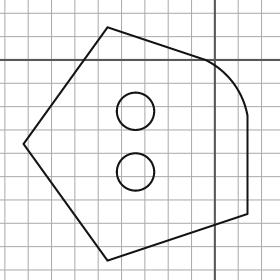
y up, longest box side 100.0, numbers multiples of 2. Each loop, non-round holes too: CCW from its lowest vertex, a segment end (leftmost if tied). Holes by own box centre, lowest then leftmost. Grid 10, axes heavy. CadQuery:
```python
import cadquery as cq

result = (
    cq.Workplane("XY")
    .moveTo(-46.0, -86.0)
    .lineTo(14.0, -66.0)
    .lineTo(14.0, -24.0)
    .threePointArc((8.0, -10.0), (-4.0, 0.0))
    .lineTo(-46.0, 14.0)
    .lineTo(-82.0, -36.0)
    .close()
    .moveTo(-34.0, -48.0)
    .circle(8.0)
    .moveTo(-34.0, -22.0)
    .circle(8.0)
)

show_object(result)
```